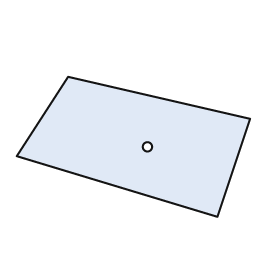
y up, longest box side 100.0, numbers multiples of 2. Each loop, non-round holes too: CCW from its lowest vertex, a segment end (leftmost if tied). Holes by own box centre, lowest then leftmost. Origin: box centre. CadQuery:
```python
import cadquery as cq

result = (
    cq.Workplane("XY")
    .moveTo(36.0, -30.0)
    .lineTo(50.0, 12.0)
    .lineTo(-28.0, 30.0)
    .lineTo(-50.0, -4.0)
    .close()
    .moveTo(6.0, 0.0)
    .circle(2.0)
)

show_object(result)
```